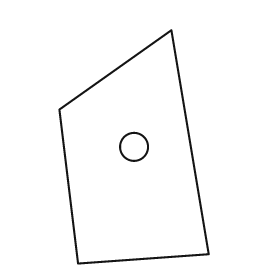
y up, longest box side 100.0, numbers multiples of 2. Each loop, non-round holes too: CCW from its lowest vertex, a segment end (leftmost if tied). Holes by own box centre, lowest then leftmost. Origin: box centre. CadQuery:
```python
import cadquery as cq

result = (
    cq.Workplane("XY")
    .moveTo(-24.0, -50.0)
    .lineTo(32.0, -46.0)
    .lineTo(16.0, 50.0)
    .lineTo(-32.0, 16.0)
    .close()
    .moveTo(0.0, 0.0)
    .circle(6.0)
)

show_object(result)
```